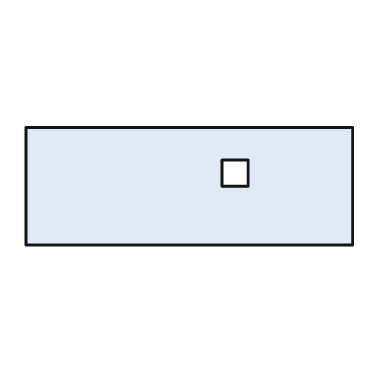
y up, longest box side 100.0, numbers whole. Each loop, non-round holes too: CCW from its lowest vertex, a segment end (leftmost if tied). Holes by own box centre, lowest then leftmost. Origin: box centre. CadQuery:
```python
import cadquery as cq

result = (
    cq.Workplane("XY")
    .moveTo(-50.0, -18.0)
    .lineTo(50.0, -18.0)
    .lineTo(50.0, 18.0)
    .lineTo(-50.0, 18.0)
    .close()
    .moveTo(10.0, 0.0)
    .lineTo(18.0, 0.0)
    .lineTo(18.0, 8.0)
    .lineTo(10.0, 8.0)
    .close()
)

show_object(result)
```